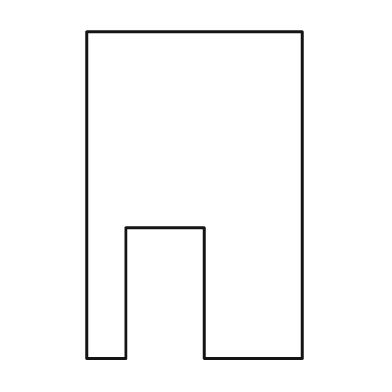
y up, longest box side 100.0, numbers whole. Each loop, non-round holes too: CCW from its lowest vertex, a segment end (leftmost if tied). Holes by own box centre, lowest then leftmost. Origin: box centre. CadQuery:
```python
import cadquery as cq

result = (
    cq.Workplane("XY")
    .moveTo(-33.0, -50.0)
    .lineTo(-21.0, -50.0)
    .lineTo(-21.0, -10.0)
    .lineTo(3.0, -10.0)
    .lineTo(3.0, -50.0)
    .lineTo(33.0, -50.0)
    .lineTo(33.0, 50.0)
    .lineTo(-33.0, 50.0)
    .close()
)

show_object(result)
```